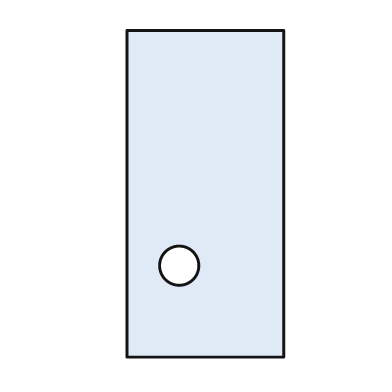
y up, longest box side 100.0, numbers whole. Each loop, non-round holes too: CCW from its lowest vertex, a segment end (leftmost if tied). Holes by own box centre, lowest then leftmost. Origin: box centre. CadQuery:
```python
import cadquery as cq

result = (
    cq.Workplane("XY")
    .moveTo(-24.0, -50.0)
    .lineTo(24.0, -50.0)
    .lineTo(24.0, 50.0)
    .lineTo(-24.0, 50.0)
    .close()
    .moveTo(-8.0, -22.0)
    .circle(6.0)
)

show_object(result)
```